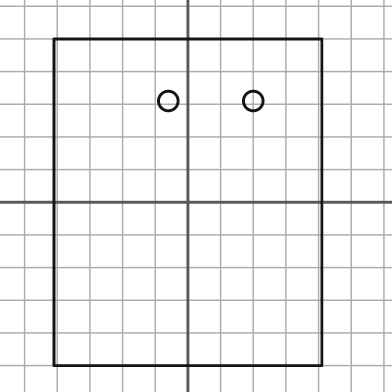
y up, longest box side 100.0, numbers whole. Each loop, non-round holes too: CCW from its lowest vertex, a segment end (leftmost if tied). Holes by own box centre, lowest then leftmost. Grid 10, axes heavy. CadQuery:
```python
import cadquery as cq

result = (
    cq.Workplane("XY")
    .moveTo(-41.0, -50.0)
    .lineTo(41.0, -50.0)
    .lineTo(41.0, 50.0)
    .lineTo(-41.0, 50.0)
    .close()
    .moveTo(-6.0, 31.0)
    .circle(3.0)
    .moveTo(20.0, 31.0)
    .circle(3.0)
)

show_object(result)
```